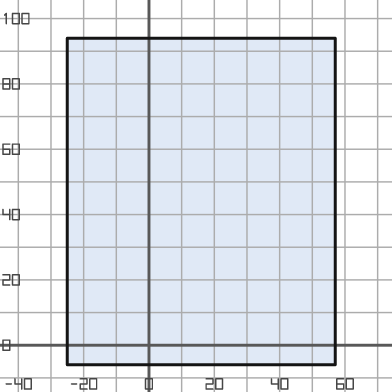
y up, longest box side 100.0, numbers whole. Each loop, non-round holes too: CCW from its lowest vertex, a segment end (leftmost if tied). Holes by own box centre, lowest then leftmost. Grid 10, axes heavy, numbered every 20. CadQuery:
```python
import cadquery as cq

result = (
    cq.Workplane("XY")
    .moveTo(-25.0, -6.0)
    .lineTo(57.0, -6.0)
    .lineTo(57.0, 94.0)
    .lineTo(-25.0, 94.0)
    .close()
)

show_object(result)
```